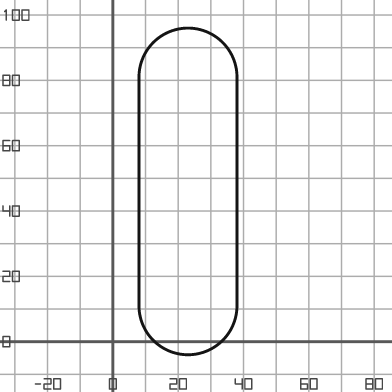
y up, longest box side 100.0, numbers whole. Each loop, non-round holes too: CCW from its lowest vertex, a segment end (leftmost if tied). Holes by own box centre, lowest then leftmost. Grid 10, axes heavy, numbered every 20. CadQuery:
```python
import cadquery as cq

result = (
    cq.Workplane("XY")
    .moveTo(8.0, 11.0)
    .threePointArc((23.0, -4.0), (38.0, 11.0))
    .lineTo(38.0, 81.0)
    .threePointArc((23.0, 96.0), (8.0, 81.0))
    .close()
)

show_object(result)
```